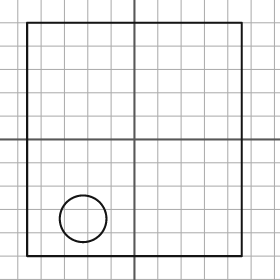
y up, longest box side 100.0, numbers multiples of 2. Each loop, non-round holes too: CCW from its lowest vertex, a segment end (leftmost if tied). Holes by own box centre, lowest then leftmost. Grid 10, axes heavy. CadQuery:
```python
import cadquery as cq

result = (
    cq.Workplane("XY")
    .moveTo(-46.0, -50.0)
    .lineTo(46.0, -50.0)
    .lineTo(46.0, 50.0)
    .lineTo(-46.0, 50.0)
    .close()
    .moveTo(-22.0, -34.0)
    .circle(10.0)
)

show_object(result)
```